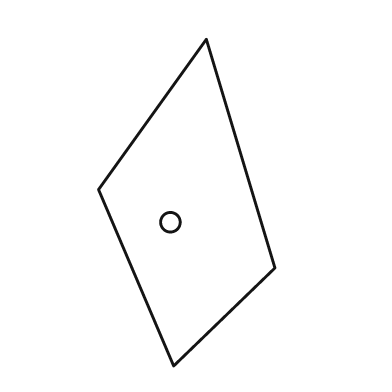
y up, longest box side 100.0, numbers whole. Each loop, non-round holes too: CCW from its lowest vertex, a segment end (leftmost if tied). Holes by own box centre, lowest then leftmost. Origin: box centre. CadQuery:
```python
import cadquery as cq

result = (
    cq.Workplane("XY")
    .moveTo(-4.0, -50.0)
    .lineTo(27.0, -20.0)
    .lineTo(6.0, 50.0)
    .lineTo(-27.0, 4.0)
    .close()
    .moveTo(-5.0, -6.0)
    .circle(3.0)
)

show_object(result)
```